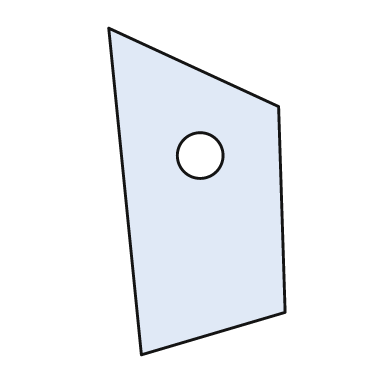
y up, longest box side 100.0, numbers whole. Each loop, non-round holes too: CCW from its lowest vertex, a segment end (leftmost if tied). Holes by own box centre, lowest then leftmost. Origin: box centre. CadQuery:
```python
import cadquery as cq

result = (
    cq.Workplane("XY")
    .moveTo(-17.0, -50.0)
    .lineTo(27.0, -37.0)
    .lineTo(25.0, 26.0)
    .lineTo(-27.0, 50.0)
    .close()
    .moveTo(1.0, 11.0)
    .circle(7.0)
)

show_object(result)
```